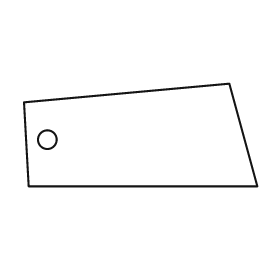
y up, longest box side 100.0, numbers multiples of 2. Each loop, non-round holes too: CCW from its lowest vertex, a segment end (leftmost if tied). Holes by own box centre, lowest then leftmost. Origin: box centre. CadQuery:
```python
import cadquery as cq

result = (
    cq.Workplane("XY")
    .moveTo(-48.0, -22.0)
    .lineTo(50.0, -22.0)
    .lineTo(38.0, 22.0)
    .lineTo(-50.0, 14.0)
    .close()
    .moveTo(-40.0, -2.0)
    .circle(4.0)
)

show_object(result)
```